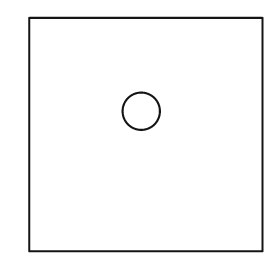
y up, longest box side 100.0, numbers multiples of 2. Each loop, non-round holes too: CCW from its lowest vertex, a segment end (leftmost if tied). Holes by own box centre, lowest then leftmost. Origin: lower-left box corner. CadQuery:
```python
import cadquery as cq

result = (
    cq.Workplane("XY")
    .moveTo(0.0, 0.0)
    .lineTo(100.0, 0.0)
    .lineTo(100.0, 100.0)
    .lineTo(0.0, 100.0)
    .close()
    .moveTo(48.0, 60.0)
    .circle(8.0)
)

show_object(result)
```